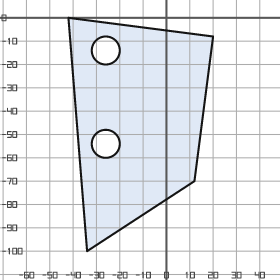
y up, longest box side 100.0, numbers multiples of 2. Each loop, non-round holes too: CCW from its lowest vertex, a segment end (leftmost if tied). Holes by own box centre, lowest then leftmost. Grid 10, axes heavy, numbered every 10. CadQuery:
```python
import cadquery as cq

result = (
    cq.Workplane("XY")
    .moveTo(-34.0, -100.0)
    .lineTo(12.0, -70.0)
    .lineTo(20.0, -8.0)
    .lineTo(-42.0, 0.0)
    .close()
    .moveTo(-26.0, -54.0)
    .circle(6.0)
    .moveTo(-26.0, -14.0)
    .circle(6.0)
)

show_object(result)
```